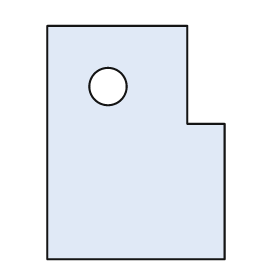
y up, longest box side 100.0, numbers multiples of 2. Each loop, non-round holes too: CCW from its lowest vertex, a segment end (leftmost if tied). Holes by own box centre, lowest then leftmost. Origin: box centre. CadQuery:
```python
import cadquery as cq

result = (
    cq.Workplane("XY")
    .moveTo(-38.0, -50.0)
    .lineTo(38.0, -50.0)
    .lineTo(38.0, 8.0)
    .lineTo(22.0, 8.0)
    .lineTo(22.0, 50.0)
    .lineTo(-38.0, 50.0)
    .close()
    .moveTo(-12.0, 24.0)
    .circle(8.0)
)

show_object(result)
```